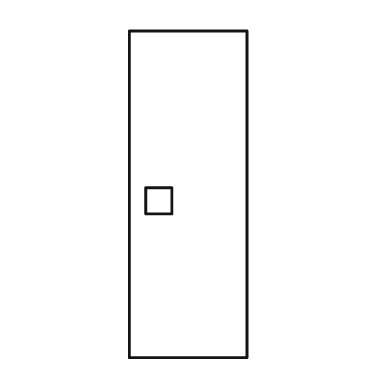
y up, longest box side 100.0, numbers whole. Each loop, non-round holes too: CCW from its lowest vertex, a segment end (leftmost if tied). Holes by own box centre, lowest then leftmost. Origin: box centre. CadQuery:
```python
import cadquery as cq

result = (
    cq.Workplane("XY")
    .moveTo(-18.0, -50.0)
    .lineTo(18.0, -50.0)
    .lineTo(18.0, 50.0)
    .lineTo(-18.0, 50.0)
    .close()
    .moveTo(-13.0, -6.0)
    .lineTo(-5.0, -6.0)
    .lineTo(-5.0, 2.0)
    .lineTo(-13.0, 2.0)
    .close()
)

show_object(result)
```